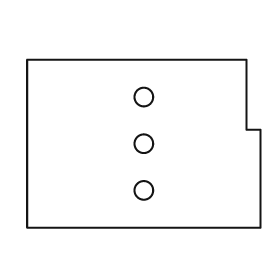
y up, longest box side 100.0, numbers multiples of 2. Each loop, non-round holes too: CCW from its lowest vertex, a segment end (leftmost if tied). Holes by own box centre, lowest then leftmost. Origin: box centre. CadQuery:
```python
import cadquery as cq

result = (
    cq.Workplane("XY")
    .moveTo(-50.0, -36.0)
    .lineTo(50.0, -36.0)
    .lineTo(50.0, 6.0)
    .lineTo(44.0, 6.0)
    .lineTo(44.0, 36.0)
    .lineTo(-50.0, 36.0)
    .close()
    .moveTo(0.0, -20.0)
    .circle(4.0)
    .moveTo(0.0, 0.0)
    .circle(4.0)
    .moveTo(0.0, 20.0)
    .circle(4.0)
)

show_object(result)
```